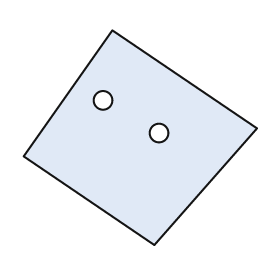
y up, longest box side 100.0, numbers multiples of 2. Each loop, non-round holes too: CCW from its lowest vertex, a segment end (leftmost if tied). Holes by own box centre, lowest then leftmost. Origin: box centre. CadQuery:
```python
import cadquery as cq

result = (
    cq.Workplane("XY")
    .moveTo(6.0, -46.0)
    .lineTo(50.0, 4.0)
    .lineTo(-12.0, 46.0)
    .lineTo(-50.0, -8.0)
    .close()
    .moveTo(8.0, 2.0)
    .circle(4.0)
    .moveTo(-16.0, 16.0)
    .circle(4.0)
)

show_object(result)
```